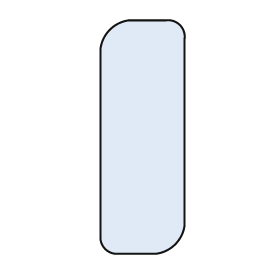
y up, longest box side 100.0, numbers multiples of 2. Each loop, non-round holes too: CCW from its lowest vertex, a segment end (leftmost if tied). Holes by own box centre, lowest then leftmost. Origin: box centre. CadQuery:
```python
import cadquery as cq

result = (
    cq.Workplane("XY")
    .moveTo(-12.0, -50.0)
    .lineTo(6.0, -50.0)
    .threePointArc((14.0, -46.0), (18.0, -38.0))
    .lineTo(18.0, 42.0)
    .threePointArc((16.0, 48.0), (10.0, 50.0))
    .lineTo(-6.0, 50.0)
    .threePointArc((-14.0, 46.0), (-18.0, 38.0))
    .lineTo(-18.0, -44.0)
    .threePointArc((-16.0, -48.0), (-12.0, -50.0))
    .close()
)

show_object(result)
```